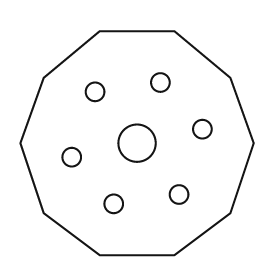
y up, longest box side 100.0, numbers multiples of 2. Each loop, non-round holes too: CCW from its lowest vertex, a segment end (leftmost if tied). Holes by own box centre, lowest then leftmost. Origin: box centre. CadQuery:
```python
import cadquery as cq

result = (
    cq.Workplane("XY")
    .moveTo(-16.0, -48.0)
    .lineTo(16.0, -48.0)
    .lineTo(40.0, -30.0)
    .lineTo(50.0, 0.0)
    .lineTo(40.0, 28.0)
    .lineTo(16.0, 48.0)
    .lineTo(-16.0, 48.0)
    .lineTo(-40.0, 28.0)
    .lineTo(-50.0, 0.0)
    .lineTo(-40.0, -30.0)
    .close()
    .moveTo(-10.0, -26.0)
    .circle(4.0)
    .moveTo(18.0, -22.0)
    .circle(4.0)
    .moveTo(-28.0, -6.0)
    .circle(4.0)
    .moveTo(0.0, 0.0)
    .circle(8.0)
    .moveTo(28.0, 6.0)
    .circle(4.0)
    .moveTo(-18.0, 22.0)
    .circle(4.0)
    .moveTo(10.0, 26.0)
    .circle(4.0)
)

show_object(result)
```